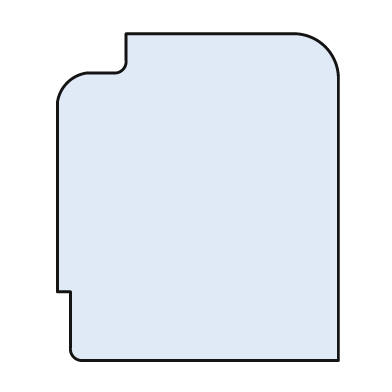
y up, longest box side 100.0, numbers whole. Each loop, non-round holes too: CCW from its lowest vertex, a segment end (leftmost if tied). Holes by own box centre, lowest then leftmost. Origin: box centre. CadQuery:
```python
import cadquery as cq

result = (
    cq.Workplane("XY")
    .moveTo(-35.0, -50.0)
    .lineTo(43.0, -50.0)
    .lineTo(43.0, 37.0)
    .threePointArc((39.0, 46.0), (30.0, 50.0))
    .lineTo(-22.0, 50.0)
    .lineTo(-22.0, 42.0)
    .threePointArc((-23.0, 39.0), (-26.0, 38.0))
    .lineTo(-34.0, 38.0)
    .threePointArc((-40.0, 35.0), (-43.0, 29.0))
    .lineTo(-43.0, -29.0)
    .lineTo(-39.0, -29.0)
    .lineTo(-39.0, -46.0)
    .threePointArc((-38.0, -49.0), (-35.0, -50.0))
    .close()
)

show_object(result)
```